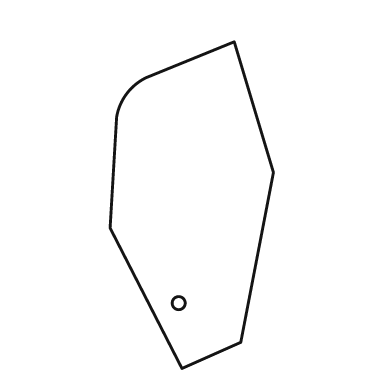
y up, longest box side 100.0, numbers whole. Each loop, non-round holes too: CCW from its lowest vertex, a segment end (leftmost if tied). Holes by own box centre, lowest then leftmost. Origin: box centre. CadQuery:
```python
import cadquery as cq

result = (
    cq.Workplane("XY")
    .moveTo(-3.0, -50.0)
    .lineTo(15.0, -42.0)
    .lineTo(25.0, 10.0)
    .lineTo(13.0, 50.0)
    .lineTo(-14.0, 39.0)
    .threePointArc((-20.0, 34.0), (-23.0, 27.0))
    .lineTo(-25.0, -7.0)
    .close()
    .moveTo(-4.0, -30.0)
    .circle(2.0)
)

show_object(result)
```